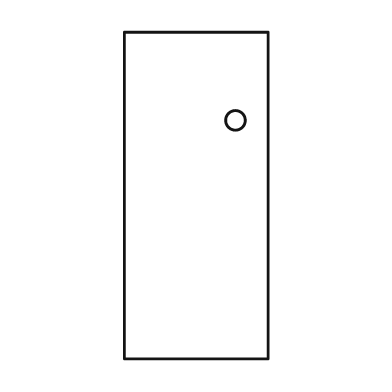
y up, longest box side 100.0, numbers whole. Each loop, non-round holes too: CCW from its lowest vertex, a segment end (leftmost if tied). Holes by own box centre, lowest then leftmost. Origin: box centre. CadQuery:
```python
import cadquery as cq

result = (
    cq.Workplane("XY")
    .moveTo(-22.0, -50.0)
    .lineTo(22.0, -50.0)
    .lineTo(22.0, 50.0)
    .lineTo(-22.0, 50.0)
    .close()
    .moveTo(12.0, 23.0)
    .circle(3.0)
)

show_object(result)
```